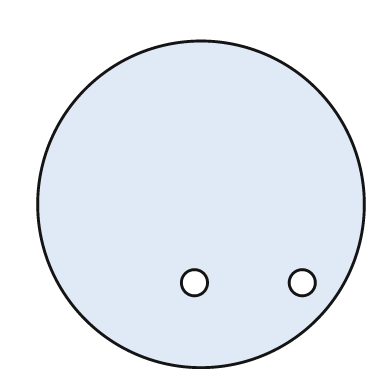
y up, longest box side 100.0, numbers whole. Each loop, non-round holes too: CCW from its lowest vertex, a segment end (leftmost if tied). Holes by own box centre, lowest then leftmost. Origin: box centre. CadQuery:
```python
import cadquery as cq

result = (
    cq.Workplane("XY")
    .moveTo(0.0, 0.0)
    .circle(50.0)
    .moveTo(-2.0, -24.0)
    .circle(4.0)
    .moveTo(31.0, -24.0)
    .circle(4.0)
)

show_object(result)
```